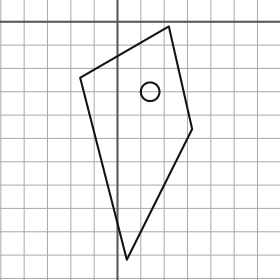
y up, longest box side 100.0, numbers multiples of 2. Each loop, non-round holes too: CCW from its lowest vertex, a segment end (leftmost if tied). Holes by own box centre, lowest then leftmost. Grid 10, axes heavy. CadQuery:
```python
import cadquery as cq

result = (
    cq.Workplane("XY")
    .moveTo(4.0, -102.0)
    .lineTo(32.0, -46.0)
    .lineTo(22.0, -2.0)
    .lineTo(-16.0, -24.0)
    .close()
    .moveTo(14.0, -30.0)
    .circle(4.0)
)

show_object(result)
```